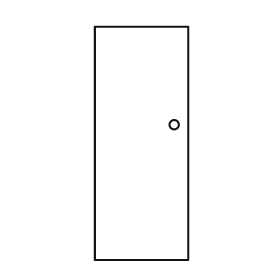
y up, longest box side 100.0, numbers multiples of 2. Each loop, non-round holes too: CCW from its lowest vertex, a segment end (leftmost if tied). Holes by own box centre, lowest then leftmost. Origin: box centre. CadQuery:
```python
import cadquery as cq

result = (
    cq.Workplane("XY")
    .moveTo(-20.0, -50.0)
    .lineTo(20.0, -50.0)
    .lineTo(20.0, 50.0)
    .lineTo(-20.0, 50.0)
    .close()
    .moveTo(14.0, 8.0)
    .circle(2.0)
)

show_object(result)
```